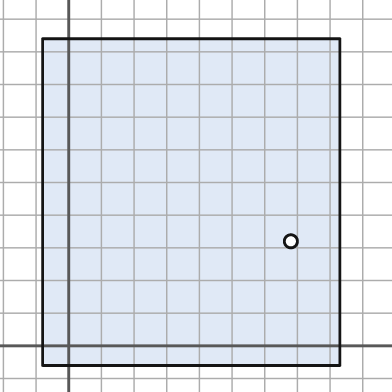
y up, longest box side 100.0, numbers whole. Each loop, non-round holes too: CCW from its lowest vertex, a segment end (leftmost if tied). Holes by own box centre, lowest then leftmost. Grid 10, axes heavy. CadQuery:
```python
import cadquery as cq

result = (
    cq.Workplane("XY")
    .moveTo(-8.0, -6.0)
    .lineTo(83.0, -6.0)
    .lineTo(83.0, 94.0)
    .lineTo(-8.0, 94.0)
    .close()
    .moveTo(68.0, 32.0)
    .circle(2.0)
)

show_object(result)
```